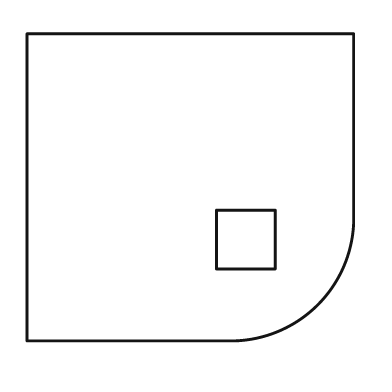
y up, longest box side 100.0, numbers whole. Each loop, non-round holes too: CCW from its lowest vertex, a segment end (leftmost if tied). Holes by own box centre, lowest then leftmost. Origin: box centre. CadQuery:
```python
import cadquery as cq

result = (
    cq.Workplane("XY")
    .moveTo(-50.0, -47.0)
    .lineTo(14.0, -47.0)
    .threePointArc((39.0, -36.0), (50.0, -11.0))
    .lineTo(50.0, 47.0)
    .lineTo(-50.0, 47.0)
    .close()
    .moveTo(8.0, -25.0)
    .lineTo(26.0, -25.0)
    .lineTo(26.0, -7.0)
    .lineTo(8.0, -7.0)
    .close()
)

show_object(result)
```